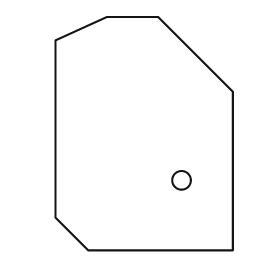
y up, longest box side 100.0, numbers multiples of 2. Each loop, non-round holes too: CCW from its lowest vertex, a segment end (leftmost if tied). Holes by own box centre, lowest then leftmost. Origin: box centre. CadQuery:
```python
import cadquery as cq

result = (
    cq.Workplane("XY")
    .moveTo(-24.0, -50.0)
    .lineTo(38.0, -50.0)
    .lineTo(38.0, 18.0)
    .lineTo(6.0, 50.0)
    .lineTo(-16.0, 50.0)
    .lineTo(-38.0, 40.0)
    .lineTo(-38.0, -36.0)
    .close()
    .moveTo(16.0, -20.0)
    .circle(4.0)
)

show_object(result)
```